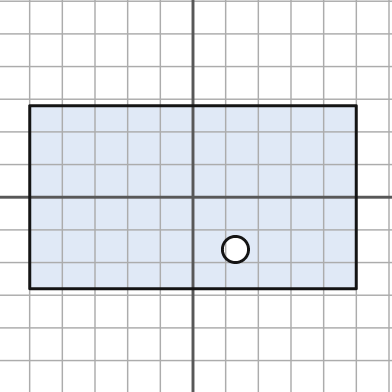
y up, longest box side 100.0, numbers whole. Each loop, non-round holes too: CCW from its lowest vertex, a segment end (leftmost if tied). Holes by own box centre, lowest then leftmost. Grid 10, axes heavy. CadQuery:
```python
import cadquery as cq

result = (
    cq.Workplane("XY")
    .moveTo(-50.0, -28.0)
    .lineTo(50.0, -28.0)
    .lineTo(50.0, 28.0)
    .lineTo(-50.0, 28.0)
    .close()
    .moveTo(13.0, -16.0)
    .circle(4.0)
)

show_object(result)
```